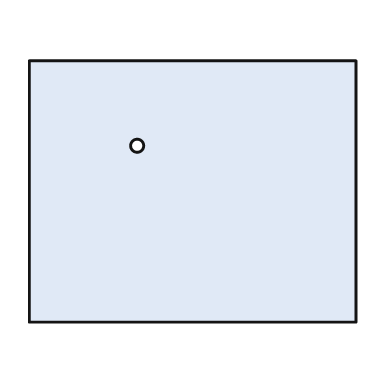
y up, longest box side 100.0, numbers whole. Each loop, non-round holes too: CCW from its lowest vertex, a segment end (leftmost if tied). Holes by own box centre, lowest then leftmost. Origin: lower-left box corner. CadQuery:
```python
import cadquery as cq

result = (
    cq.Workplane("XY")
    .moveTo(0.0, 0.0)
    .lineTo(100.0, 0.0)
    .lineTo(100.0, 80.0)
    .lineTo(0.0, 80.0)
    .close()
    .moveTo(33.0, 54.0)
    .circle(2.0)
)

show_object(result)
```